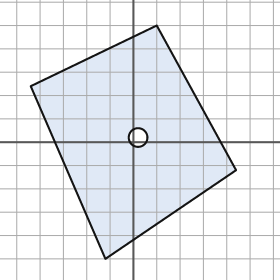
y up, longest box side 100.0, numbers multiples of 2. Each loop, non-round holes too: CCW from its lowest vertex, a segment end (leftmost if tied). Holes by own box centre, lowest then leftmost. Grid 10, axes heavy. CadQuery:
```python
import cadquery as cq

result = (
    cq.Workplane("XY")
    .moveTo(-12.0, -50.0)
    .lineTo(44.0, -12.0)
    .lineTo(10.0, 50.0)
    .lineTo(-44.0, 24.0)
    .close()
    .moveTo(2.0, 2.0)
    .circle(4.0)
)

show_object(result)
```